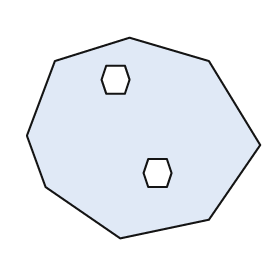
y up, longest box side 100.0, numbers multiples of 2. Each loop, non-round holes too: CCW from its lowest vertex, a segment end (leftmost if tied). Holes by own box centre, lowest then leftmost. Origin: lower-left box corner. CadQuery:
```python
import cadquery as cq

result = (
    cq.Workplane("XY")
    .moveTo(40.0, 0.0)
    .lineTo(78.0, 8.0)
    .lineTo(100.0, 40.0)
    .lineTo(78.0, 76.0)
    .lineTo(44.0, 86.0)
    .lineTo(12.0, 76.0)
    .lineTo(0.0, 44.0)
    .lineTo(8.0, 22.0)
    .close()
    .moveTo(52.0, 22.0)
    .lineTo(60.0, 22.0)
    .lineTo(62.0, 28.0)
    .lineTo(60.0, 34.0)
    .lineTo(52.0, 34.0)
    .lineTo(50.0, 28.0)
    .close()
    .moveTo(34.0, 62.0)
    .lineTo(42.0, 62.0)
    .lineTo(44.0, 68.0)
    .lineTo(42.0, 74.0)
    .lineTo(34.0, 74.0)
    .lineTo(32.0, 68.0)
    .close()
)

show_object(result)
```